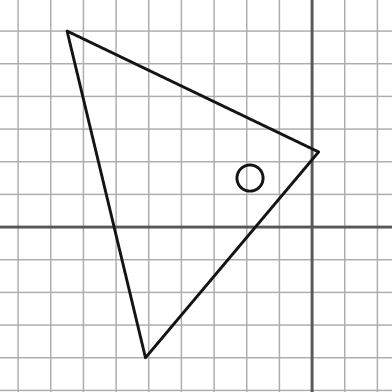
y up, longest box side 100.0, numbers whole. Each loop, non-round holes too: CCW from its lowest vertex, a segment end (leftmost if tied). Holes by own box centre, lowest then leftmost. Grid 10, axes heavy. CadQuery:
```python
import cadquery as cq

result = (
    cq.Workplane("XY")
    .moveTo(-51.0, -40.0)
    .lineTo(2.0, 23.0)
    .lineTo(-75.0, 60.0)
    .close()
    .moveTo(-19.0, 15.0)
    .circle(4.0)
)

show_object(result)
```